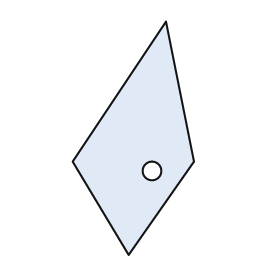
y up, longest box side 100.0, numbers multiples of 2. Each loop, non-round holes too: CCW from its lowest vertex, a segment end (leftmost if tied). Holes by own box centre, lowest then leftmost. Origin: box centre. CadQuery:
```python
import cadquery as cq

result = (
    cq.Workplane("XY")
    .moveTo(-2.0, -50.0)
    .lineTo(26.0, -10.0)
    .lineTo(14.0, 50.0)
    .lineTo(-26.0, -10.0)
    .close()
    .moveTo(8.0, -14.0)
    .circle(4.0)
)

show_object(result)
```